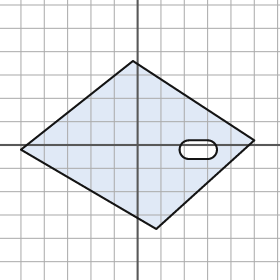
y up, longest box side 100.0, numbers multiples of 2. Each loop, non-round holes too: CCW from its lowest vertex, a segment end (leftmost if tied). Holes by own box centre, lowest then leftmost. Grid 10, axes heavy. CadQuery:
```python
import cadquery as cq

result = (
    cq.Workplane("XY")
    .moveTo(8.0, -36.0)
    .lineTo(50.0, 2.0)
    .lineTo(-2.0, 36.0)
    .lineTo(-50.0, -2.0)
    .close()
    .moveTo(22.0, -6.0)
    .lineTo(30.0, -6.0)
    .threePointArc((34.0, -2.0), (30.0, 2.0))
    .lineTo(22.0, 2.0)
    .threePointArc((18.0, -2.0), (22.0, -6.0))
    .close()
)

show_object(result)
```